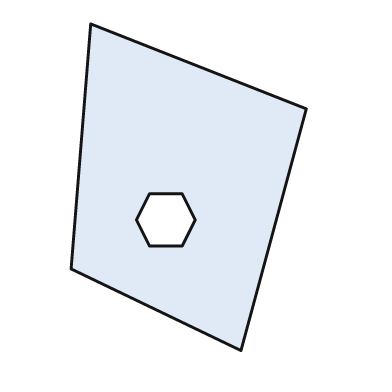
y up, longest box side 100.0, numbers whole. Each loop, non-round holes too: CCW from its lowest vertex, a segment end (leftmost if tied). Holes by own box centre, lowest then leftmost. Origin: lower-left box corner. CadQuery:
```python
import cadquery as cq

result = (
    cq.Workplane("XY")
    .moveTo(52.0, 0.0)
    .lineTo(72.0, 74.0)
    .lineTo(6.0, 100.0)
    .lineTo(0.0, 25.0)
    .close()
    .moveTo(24.0, 32.0)
    .lineTo(34.0, 32.0)
    .lineTo(38.0, 40.0)
    .lineTo(34.0, 48.0)
    .lineTo(24.0, 48.0)
    .lineTo(20.0, 40.0)
    .close()
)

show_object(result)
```